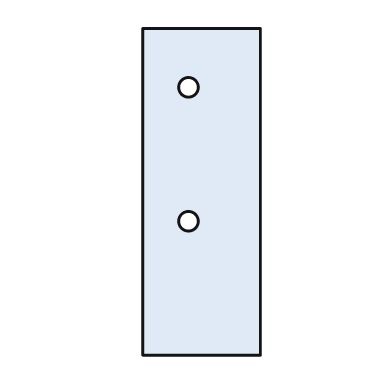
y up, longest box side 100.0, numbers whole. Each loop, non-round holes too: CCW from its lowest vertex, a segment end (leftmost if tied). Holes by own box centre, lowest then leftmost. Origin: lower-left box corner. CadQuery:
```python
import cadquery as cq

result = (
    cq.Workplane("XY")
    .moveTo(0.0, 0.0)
    .lineTo(36.0, 0.0)
    .lineTo(36.0, 100.0)
    .lineTo(0.0, 100.0)
    .close()
    .moveTo(14.0, 41.0)
    .circle(3.0)
    .moveTo(14.0, 82.0)
    .circle(3.0)
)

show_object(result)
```